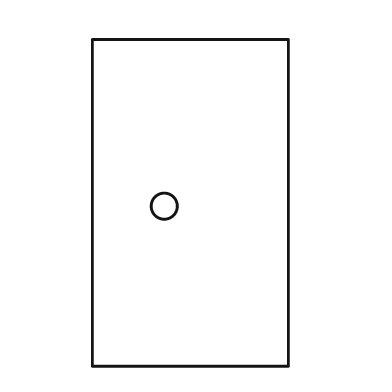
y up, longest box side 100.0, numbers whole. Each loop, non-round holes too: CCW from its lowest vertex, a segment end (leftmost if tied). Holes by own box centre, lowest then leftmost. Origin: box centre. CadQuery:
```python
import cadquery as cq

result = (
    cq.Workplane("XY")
    .moveTo(-30.0, -50.0)
    .lineTo(30.0, -50.0)
    .lineTo(30.0, 50.0)
    .lineTo(-30.0, 50.0)
    .close()
    .moveTo(-8.0, -1.0)
    .circle(4.0)
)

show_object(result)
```